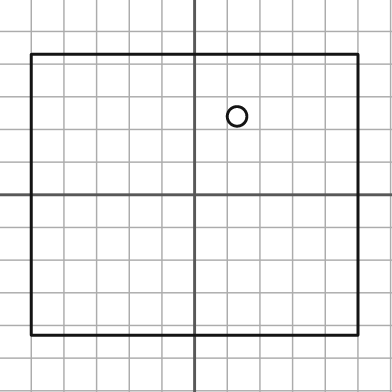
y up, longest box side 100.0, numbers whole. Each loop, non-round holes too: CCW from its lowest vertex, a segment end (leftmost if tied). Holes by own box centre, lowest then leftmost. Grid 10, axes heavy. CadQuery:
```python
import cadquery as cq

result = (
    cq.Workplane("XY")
    .moveTo(-50.0, -43.0)
    .lineTo(50.0, -43.0)
    .lineTo(50.0, 43.0)
    .lineTo(-50.0, 43.0)
    .close()
    .moveTo(13.0, 24.0)
    .circle(3.0)
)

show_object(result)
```